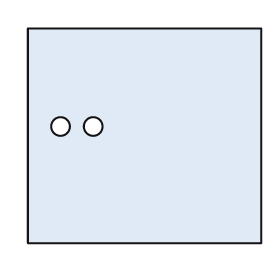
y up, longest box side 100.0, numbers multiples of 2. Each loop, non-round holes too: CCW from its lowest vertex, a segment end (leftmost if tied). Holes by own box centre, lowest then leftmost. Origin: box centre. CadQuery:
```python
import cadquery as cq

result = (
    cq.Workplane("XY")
    .moveTo(-50.0, -46.0)
    .lineTo(50.0, -46.0)
    .lineTo(50.0, 46.0)
    .lineTo(-50.0, 46.0)
    .close()
    .moveTo(-36.0, 4.0)
    .circle(4.0)
    .moveTo(-22.0, 4.0)
    .circle(4.0)
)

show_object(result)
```